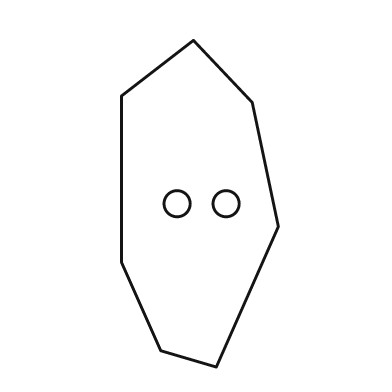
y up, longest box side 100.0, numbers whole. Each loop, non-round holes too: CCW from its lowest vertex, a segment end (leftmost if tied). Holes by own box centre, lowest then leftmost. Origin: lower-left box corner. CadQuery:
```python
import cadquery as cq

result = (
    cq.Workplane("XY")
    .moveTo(29.0, 0.0)
    .lineTo(48.0, 43.0)
    .lineTo(40.0, 81.0)
    .lineTo(22.0, 100.0)
    .lineTo(0.0, 83.0)
    .lineTo(0.0, 32.0)
    .lineTo(12.0, 5.0)
    .close()
    .moveTo(17.0, 50.0)
    .circle(4.0)
    .moveTo(32.0, 50.0)
    .circle(4.0)
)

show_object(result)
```